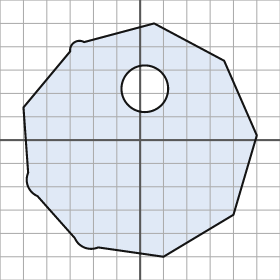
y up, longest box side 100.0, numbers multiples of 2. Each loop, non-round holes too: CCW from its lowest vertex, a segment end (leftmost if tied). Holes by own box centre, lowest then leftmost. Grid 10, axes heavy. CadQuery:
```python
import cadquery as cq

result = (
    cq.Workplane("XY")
    .moveTo(10.0, -50.0)
    .lineTo(40.0, -32.0)
    .lineTo(50.0, 2.0)
    .lineTo(36.0, 34.0)
    .lineTo(6.0, 50.0)
    .lineTo(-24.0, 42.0)
    .threePointArc((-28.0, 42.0), (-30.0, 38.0))
    .lineTo(-50.0, 14.0)
    .lineTo(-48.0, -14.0)
    .threePointArc((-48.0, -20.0), (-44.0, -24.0))
    .lineTo(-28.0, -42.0)
    .threePointArc((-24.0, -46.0), (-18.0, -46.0))
    .close()
    .moveTo(2.0, 22.0)
    .circle(10.0)
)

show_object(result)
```